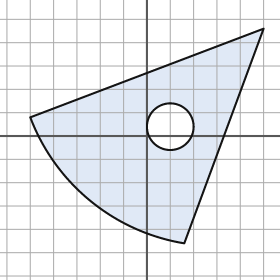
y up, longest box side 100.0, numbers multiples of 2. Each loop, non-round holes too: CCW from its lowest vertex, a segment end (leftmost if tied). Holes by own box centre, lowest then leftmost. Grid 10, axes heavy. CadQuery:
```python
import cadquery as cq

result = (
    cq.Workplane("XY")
    .moveTo(16.0, -46.0)
    .lineTo(50.0, 46.0)
    .lineTo(-50.0, 8.0)
    .threePointArc((-24.0, -28.0), (16.0, -46.0))
    .close()
    .moveTo(10.0, 4.0)
    .circle(10.0)
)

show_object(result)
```